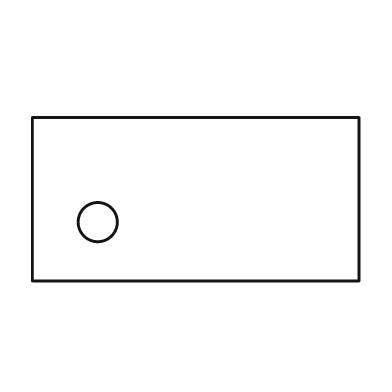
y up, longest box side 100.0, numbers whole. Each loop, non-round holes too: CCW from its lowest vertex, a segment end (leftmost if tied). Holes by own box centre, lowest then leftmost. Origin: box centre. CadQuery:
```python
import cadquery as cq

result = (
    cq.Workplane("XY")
    .moveTo(-50.0, -25.0)
    .lineTo(50.0, -25.0)
    .lineTo(50.0, 25.0)
    .lineTo(-50.0, 25.0)
    .close()
    .moveTo(-30.0, -7.0)
    .circle(6.0)
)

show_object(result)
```